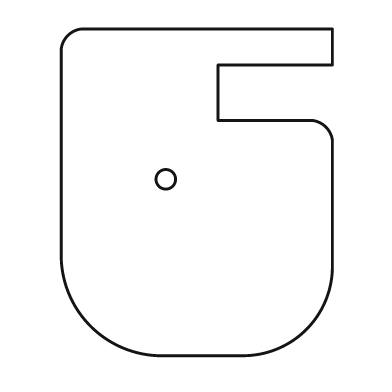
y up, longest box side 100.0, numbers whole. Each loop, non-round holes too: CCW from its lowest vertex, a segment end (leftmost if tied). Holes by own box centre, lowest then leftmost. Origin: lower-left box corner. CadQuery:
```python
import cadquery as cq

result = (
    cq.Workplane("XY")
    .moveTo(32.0, 0.0)
    .lineTo(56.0, 0.0)
    .threePointArc((75.0, 8.0), (83.0, 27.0))
    .lineTo(83.0, 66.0)
    .threePointArc((81.0, 70.0), (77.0, 72.0))
    .lineTo(48.0, 72.0)
    .lineTo(48.0, 89.0)
    .lineTo(83.0, 89.0)
    .lineTo(83.0, 100.0)
    .lineTo(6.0, 100.0)
    .threePointArc((2.0, 98.0), (0.0, 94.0))
    .lineTo(0.0, 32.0)
    .threePointArc((9.0, 9.0), (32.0, 0.0))
    .close()
    .moveTo(32.0, 54.0)
    .circle(3.0)
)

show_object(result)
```